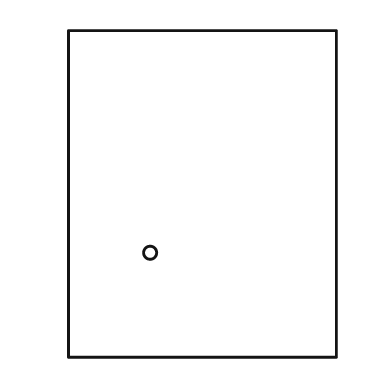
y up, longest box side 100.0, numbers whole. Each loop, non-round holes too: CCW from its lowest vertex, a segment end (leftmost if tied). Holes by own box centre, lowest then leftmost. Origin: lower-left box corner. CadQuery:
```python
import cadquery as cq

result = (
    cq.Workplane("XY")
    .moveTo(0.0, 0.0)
    .lineTo(82.0, 0.0)
    .lineTo(82.0, 100.0)
    .lineTo(0.0, 100.0)
    .close()
    .moveTo(25.0, 32.0)
    .circle(2.0)
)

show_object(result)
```